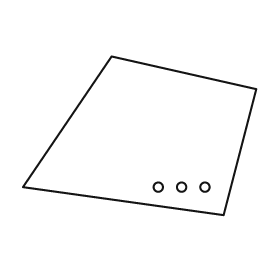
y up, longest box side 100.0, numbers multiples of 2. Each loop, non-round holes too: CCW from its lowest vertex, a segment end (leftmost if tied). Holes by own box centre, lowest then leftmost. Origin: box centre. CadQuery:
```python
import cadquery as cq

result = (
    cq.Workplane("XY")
    .moveTo(36.0, -34.0)
    .lineTo(50.0, 20.0)
    .lineTo(-12.0, 34.0)
    .lineTo(-50.0, -22.0)
    .close()
    .moveTo(8.0, -22.0)
    .circle(2.0)
    .moveTo(18.0, -22.0)
    .circle(2.0)
    .moveTo(28.0, -22.0)
    .circle(2.0)
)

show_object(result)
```